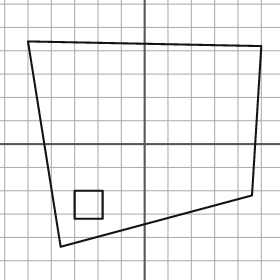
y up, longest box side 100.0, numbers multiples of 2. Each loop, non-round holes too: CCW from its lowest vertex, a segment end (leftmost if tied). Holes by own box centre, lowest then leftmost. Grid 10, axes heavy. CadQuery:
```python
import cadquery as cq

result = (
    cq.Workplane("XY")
    .moveTo(-36.0, -44.0)
    .lineTo(46.0, -22.0)
    .lineTo(50.0, 42.0)
    .lineTo(-50.0, 44.0)
    .close()
    .moveTo(-30.0, -32.0)
    .lineTo(-18.0, -32.0)
    .lineTo(-18.0, -20.0)
    .lineTo(-30.0, -20.0)
    .close()
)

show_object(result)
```